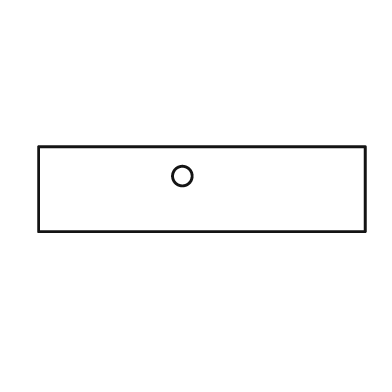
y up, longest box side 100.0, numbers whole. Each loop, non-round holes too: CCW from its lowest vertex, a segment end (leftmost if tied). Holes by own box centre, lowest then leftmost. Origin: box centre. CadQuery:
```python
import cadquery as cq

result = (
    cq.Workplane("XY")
    .moveTo(-50.0, -13.0)
    .lineTo(50.0, -13.0)
    .lineTo(50.0, 13.0)
    .lineTo(-50.0, 13.0)
    .close()
    .moveTo(-6.0, 4.0)
    .circle(3.0)
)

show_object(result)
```